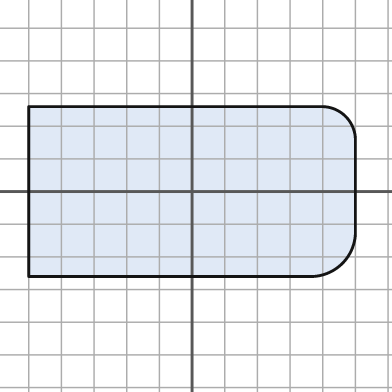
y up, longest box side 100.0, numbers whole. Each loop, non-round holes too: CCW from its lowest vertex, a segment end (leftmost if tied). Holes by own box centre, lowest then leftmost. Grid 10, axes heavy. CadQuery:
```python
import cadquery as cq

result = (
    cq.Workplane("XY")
    .moveTo(-50.0, -26.0)
    .lineTo(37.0, -26.0)
    .threePointArc((46.0, -22.0), (50.0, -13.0))
    .lineTo(50.0, 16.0)
    .threePointArc((47.0, 23.0), (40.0, 26.0))
    .lineTo(-50.0, 26.0)
    .close()
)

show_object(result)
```